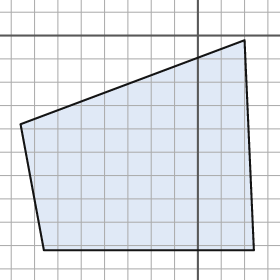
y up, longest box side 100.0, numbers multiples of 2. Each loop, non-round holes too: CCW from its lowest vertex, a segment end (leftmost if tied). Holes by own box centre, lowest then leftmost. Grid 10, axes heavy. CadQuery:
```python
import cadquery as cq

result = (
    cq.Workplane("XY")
    .moveTo(-66.0, -92.0)
    .lineTo(24.0, -92.0)
    .lineTo(20.0, -2.0)
    .lineTo(-76.0, -38.0)
    .close()
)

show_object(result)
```